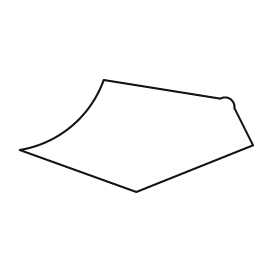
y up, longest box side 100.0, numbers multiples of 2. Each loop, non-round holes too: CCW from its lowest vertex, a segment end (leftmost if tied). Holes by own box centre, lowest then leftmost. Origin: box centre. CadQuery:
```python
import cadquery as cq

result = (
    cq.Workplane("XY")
    .moveTo(0.0, -24.0)
    .lineTo(50.0, -4.0)
    .lineTo(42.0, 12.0)
    .threePointArc((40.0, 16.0), (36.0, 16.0))
    .lineTo(-14.0, 24.0)
    .threePointArc((-28.0, 4.0), (-50.0, -6.0))
    .close()
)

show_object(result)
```